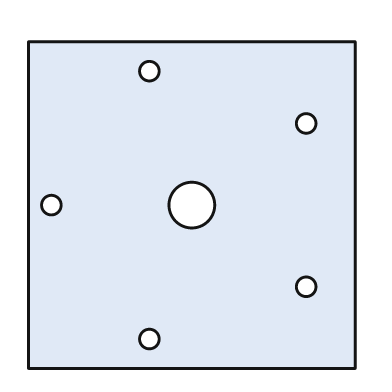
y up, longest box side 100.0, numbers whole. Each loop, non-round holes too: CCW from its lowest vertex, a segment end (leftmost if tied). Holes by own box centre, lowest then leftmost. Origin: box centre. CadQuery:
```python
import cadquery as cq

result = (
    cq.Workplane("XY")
    .moveTo(-50.0, -50.0)
    .lineTo(50.0, -50.0)
    .lineTo(50.0, 50.0)
    .lineTo(-50.0, 50.0)
    .close()
    .moveTo(-13.0, -41.0)
    .circle(3.0)
    .moveTo(35.0, -25.0)
    .circle(3.0)
    .moveTo(-43.0, 0.0)
    .circle(3.0)
    .moveTo(0.0, 0.0)
    .circle(7.0)
    .moveTo(35.0, 25.0)
    .circle(3.0)
    .moveTo(-13.0, 41.0)
    .circle(3.0)
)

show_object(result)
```